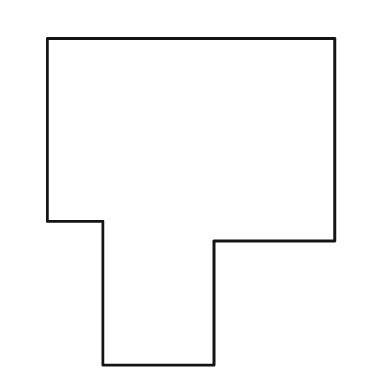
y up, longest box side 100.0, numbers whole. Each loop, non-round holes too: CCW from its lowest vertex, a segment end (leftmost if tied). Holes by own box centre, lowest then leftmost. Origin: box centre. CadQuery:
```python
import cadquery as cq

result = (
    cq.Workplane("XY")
    .moveTo(-27.0, -50.0)
    .lineTo(7.0, -50.0)
    .lineTo(7.0, -12.0)
    .lineTo(44.0, -12.0)
    .lineTo(44.0, 50.0)
    .lineTo(-44.0, 50.0)
    .lineTo(-44.0, -6.0)
    .lineTo(-27.0, -6.0)
    .close()
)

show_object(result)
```